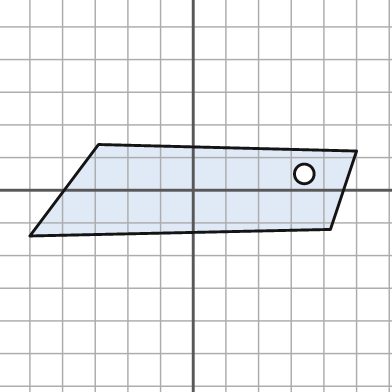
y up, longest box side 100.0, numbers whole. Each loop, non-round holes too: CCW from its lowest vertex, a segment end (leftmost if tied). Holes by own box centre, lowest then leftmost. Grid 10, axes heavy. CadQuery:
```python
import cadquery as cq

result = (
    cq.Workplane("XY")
    .moveTo(-50.0, -14.0)
    .lineTo(42.0, -12.0)
    .lineTo(50.0, 12.0)
    .lineTo(-29.0, 14.0)
    .close()
    .moveTo(34.0, 5.0)
    .circle(3.0)
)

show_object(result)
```